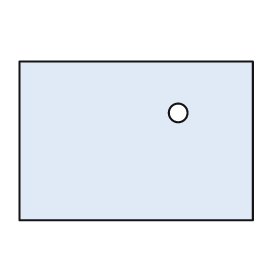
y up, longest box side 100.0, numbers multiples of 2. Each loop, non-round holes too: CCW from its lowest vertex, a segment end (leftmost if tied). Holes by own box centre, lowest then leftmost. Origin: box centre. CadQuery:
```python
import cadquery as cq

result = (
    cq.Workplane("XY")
    .moveTo(-50.0, -34.0)
    .lineTo(50.0, -34.0)
    .lineTo(50.0, 34.0)
    .lineTo(-50.0, 34.0)
    .close()
    .moveTo(18.0, 12.0)
    .circle(4.0)
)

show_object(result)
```